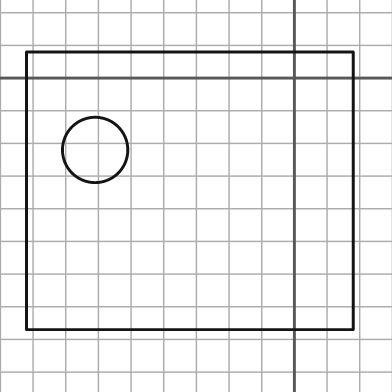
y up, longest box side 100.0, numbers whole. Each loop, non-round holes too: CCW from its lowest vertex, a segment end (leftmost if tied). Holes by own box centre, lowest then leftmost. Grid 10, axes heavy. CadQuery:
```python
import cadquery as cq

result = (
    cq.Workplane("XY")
    .moveTo(-82.0, -77.0)
    .lineTo(18.0, -77.0)
    .lineTo(18.0, 8.0)
    .lineTo(-82.0, 8.0)
    .close()
    .moveTo(-61.0, -22.0)
    .circle(10.0)
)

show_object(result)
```